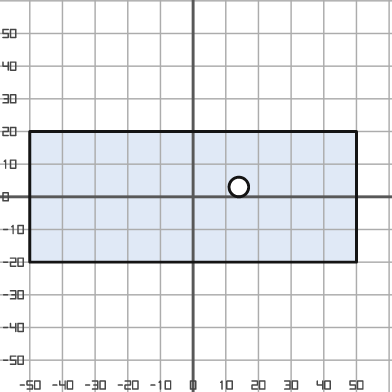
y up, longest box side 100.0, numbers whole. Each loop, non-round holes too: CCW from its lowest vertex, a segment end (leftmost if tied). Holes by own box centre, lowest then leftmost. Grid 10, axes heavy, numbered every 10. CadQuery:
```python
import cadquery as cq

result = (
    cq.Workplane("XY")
    .moveTo(-50.0, -20.0)
    .lineTo(50.0, -20.0)
    .lineTo(50.0, 20.0)
    .lineTo(-50.0, 20.0)
    .close()
    .moveTo(14.0, 3.0)
    .circle(3.0)
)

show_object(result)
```